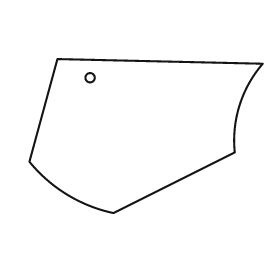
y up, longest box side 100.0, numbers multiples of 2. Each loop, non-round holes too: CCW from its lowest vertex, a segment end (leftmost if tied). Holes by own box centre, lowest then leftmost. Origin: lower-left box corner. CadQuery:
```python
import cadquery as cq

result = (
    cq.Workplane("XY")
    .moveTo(36.0, 0.0)
    .lineTo(88.0, 26.0)
    .threePointArc((90.0, 46.0), (100.0, 64.0))
    .lineTo(12.0, 66.0)
    .lineTo(0.0, 22.0)
    .threePointArc((16.0, 8.0), (36.0, 0.0))
    .close()
    .moveTo(26.0, 58.0)
    .circle(2.0)
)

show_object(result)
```